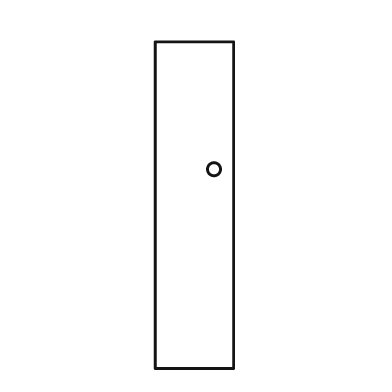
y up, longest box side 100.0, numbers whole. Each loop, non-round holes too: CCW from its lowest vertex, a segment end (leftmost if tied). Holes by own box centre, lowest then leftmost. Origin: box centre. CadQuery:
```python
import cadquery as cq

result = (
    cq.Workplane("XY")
    .moveTo(-12.0, -50.0)
    .lineTo(12.0, -50.0)
    .lineTo(12.0, 50.0)
    .lineTo(-12.0, 50.0)
    .close()
    .moveTo(6.0, 11.0)
    .circle(2.0)
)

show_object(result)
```